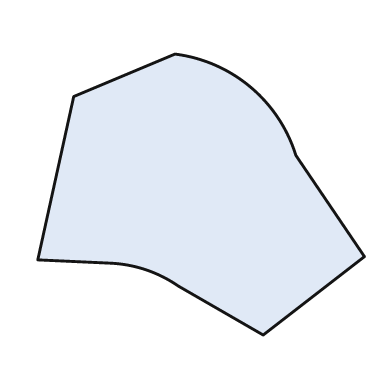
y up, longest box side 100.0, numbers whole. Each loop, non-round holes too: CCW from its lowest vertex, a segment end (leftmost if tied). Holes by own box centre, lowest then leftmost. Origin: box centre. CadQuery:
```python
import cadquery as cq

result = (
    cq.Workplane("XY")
    .moveTo(19.0, -43.0)
    .lineTo(50.0, -19.0)
    .lineTo(29.0, 12.0)
    .threePointArc((15.0, 33.0), (-8.0, 43.0))
    .lineTo(-39.0, 30.0)
    .lineTo(-50.0, -20.0)
    .lineTo(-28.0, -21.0)
    .threePointArc((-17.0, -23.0), (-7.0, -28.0))
    .close()
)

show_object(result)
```